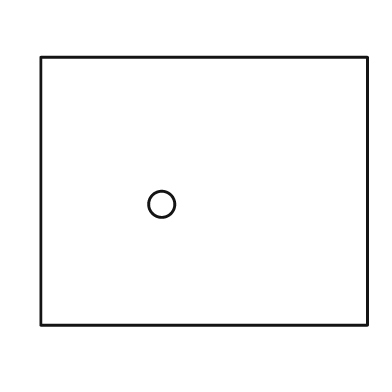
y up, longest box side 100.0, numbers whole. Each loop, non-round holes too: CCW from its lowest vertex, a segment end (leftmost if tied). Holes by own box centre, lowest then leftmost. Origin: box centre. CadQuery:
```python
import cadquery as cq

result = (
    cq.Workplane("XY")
    .moveTo(-50.0, -41.0)
    .lineTo(50.0, -41.0)
    .lineTo(50.0, 41.0)
    .lineTo(-50.0, 41.0)
    .close()
    .moveTo(-13.0, -4.0)
    .circle(4.0)
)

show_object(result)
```